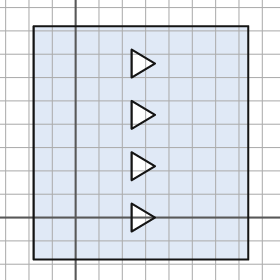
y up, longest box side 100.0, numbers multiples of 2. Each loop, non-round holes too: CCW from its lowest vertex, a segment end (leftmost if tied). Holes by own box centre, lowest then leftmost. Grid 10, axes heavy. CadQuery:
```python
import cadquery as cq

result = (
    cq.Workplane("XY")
    .moveTo(-18.0, -18.0)
    .lineTo(74.0, -18.0)
    .lineTo(74.0, 82.0)
    .lineTo(-18.0, 82.0)
    .close()
    .moveTo(24.0, -6.0)
    .lineTo(34.0, 0.0)
    .lineTo(24.0, 6.0)
    .close()
    .moveTo(24.0, 16.0)
    .lineTo(34.0, 22.0)
    .lineTo(24.0, 28.0)
    .close()
    .moveTo(24.0, 38.0)
    .lineTo(34.0, 44.0)
    .lineTo(24.0, 50.0)
    .close()
    .moveTo(24.0, 60.0)
    .lineTo(34.0, 66.0)
    .lineTo(24.0, 72.0)
    .close()
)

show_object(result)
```